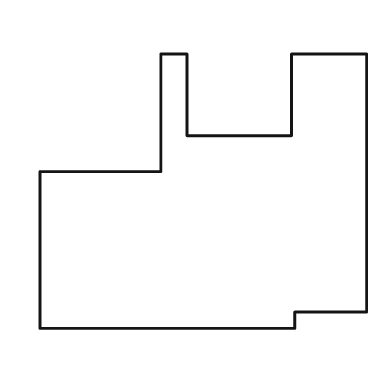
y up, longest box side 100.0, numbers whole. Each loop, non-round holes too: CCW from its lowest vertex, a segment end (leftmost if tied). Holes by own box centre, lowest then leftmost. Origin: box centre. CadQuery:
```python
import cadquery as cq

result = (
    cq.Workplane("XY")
    .moveTo(-50.0, -42.0)
    .lineTo(28.0, -42.0)
    .lineTo(28.0, -37.0)
    .lineTo(50.0, -37.0)
    .lineTo(50.0, 42.0)
    .lineTo(27.0, 42.0)
    .lineTo(27.0, 17.0)
    .lineTo(-5.0, 17.0)
    .lineTo(-5.0, 42.0)
    .lineTo(-13.0, 42.0)
    .lineTo(-13.0, 6.0)
    .lineTo(-50.0, 6.0)
    .close()
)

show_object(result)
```